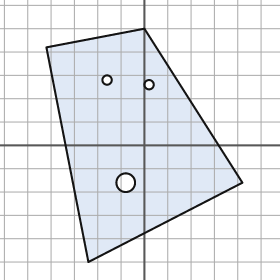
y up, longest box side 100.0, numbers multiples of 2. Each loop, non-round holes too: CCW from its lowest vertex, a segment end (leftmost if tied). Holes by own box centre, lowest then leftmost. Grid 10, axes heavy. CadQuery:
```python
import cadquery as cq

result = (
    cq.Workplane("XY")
    .moveTo(-24.0, -50.0)
    .lineTo(42.0, -16.0)
    .lineTo(0.0, 50.0)
    .lineTo(-42.0, 42.0)
    .close()
    .moveTo(-8.0, -16.0)
    .circle(4.0)
    .moveTo(2.0, 26.0)
    .circle(2.0)
    .moveTo(-16.0, 28.0)
    .circle(2.0)
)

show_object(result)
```